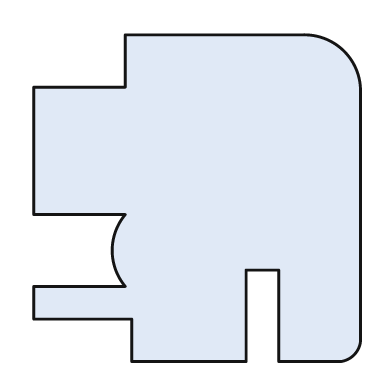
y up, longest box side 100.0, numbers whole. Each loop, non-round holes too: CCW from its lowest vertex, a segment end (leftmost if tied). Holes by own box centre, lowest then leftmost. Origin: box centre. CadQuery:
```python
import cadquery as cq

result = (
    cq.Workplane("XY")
    .moveTo(-20.0, -50.0)
    .lineTo(15.0, -50.0)
    .lineTo(15.0, -22.0)
    .lineTo(25.0, -22.0)
    .lineTo(25.0, -50.0)
    .lineTo(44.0, -50.0)
    .threePointArc((48.0, -48.0), (50.0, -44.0))
    .lineTo(50.0, 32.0)
    .threePointArc((45.0, 45.0), (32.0, 50.0))
    .lineTo(-22.0, 50.0)
    .lineTo(-22.0, 34.0)
    .lineTo(-50.0, 34.0)
    .lineTo(-50.0, -5.0)
    .lineTo(-22.0, -5.0)
    .threePointArc((-26.0, -16.0), (-22.0, -27.0))
    .lineTo(-50.0, -27.0)
    .lineTo(-50.0, -37.0)
    .lineTo(-20.0, -37.0)
    .close()
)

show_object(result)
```